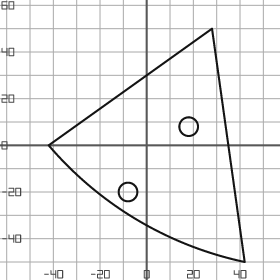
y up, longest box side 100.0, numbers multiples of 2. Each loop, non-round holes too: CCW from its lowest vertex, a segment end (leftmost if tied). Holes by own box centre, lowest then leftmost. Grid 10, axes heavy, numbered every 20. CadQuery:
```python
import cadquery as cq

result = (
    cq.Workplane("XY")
    .moveTo(42.0, -50.0)
    .lineTo(28.0, 50.0)
    .lineTo(-42.0, 0.0)
    .threePointArc((-4.0, -32.0), (42.0, -50.0))
    .close()
    .moveTo(-8.0, -20.0)
    .circle(4.0)
    .moveTo(18.0, 8.0)
    .circle(4.0)
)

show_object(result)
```